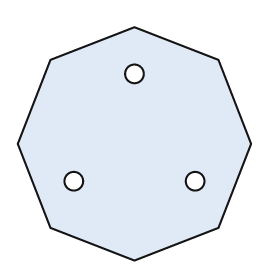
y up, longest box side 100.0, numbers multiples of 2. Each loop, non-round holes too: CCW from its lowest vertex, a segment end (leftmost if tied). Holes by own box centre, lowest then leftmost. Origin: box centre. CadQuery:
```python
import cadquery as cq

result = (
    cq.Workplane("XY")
    .moveTo(0.0, -50.0)
    .lineTo(36.0, -36.0)
    .lineTo(50.0, 0.0)
    .lineTo(36.0, 36.0)
    .lineTo(0.0, 50.0)
    .lineTo(-36.0, 36.0)
    .lineTo(-50.0, 0.0)
    .lineTo(-36.0, -36.0)
    .close()
    .moveTo(-26.0, -16.0)
    .circle(4.0)
    .moveTo(26.0, -16.0)
    .circle(4.0)
    .moveTo(0.0, 30.0)
    .circle(4.0)
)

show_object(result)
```